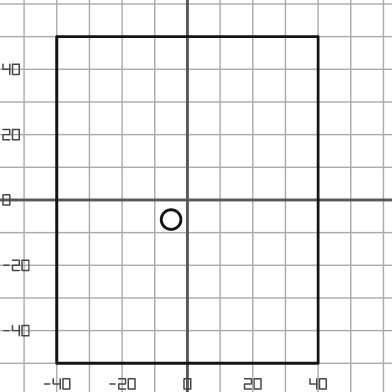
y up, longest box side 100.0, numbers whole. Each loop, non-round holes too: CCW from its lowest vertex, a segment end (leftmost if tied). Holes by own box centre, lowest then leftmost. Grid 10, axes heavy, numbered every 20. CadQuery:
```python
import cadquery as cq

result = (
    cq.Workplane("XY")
    .moveTo(-40.0, -50.0)
    .lineTo(40.0, -50.0)
    .lineTo(40.0, 50.0)
    .lineTo(-40.0, 50.0)
    .close()
    .moveTo(-5.0, -6.0)
    .circle(3.0)
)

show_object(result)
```